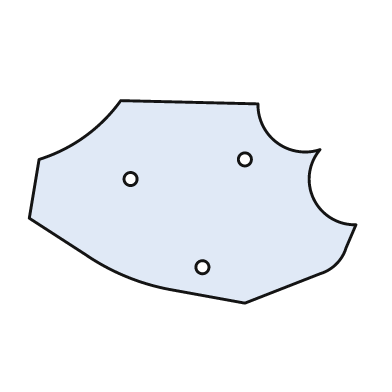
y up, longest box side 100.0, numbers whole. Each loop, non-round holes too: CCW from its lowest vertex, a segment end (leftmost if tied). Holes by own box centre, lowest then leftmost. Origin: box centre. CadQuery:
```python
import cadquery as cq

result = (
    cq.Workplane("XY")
    .moveTo(16.0, -31.0)
    .lineTo(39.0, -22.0)
    .threePointArc((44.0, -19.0), (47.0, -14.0))
    .lineTo(50.0, -7.0)
    .threePointArc((37.0, 1.0), (39.0, 16.0))
    .threePointArc((26.0, 18.0), (20.0, 30.0))
    .lineTo(-22.0, 31.0)
    .threePointArc((-33.0, 20.0), (-47.0, 13.0))
    .lineTo(-50.0, -5.0)
    .lineTo(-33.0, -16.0)
    .threePointArc((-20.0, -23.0), (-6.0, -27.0))
    .close()
    .moveTo(3.0, -20.0)
    .circle(2.0)
    .moveTo(-19.0, 7.0)
    .circle(2.0)
    .moveTo(16.0, 13.0)
    .circle(2.0)
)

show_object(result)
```